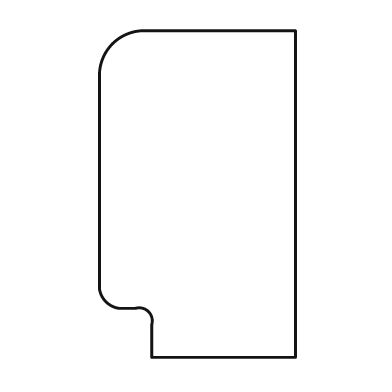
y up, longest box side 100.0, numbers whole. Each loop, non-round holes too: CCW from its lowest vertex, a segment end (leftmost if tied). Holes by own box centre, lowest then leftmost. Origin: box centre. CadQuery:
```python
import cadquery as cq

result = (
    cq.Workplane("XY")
    .moveTo(-14.0, -50.0)
    .lineTo(30.0, -50.0)
    .lineTo(30.0, 50.0)
    .lineTo(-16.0, 50.0)
    .threePointArc((-26.0, 46.0), (-30.0, 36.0))
    .lineTo(-30.0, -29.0)
    .threePointArc((-28.0, -33.0), (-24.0, -35.0))
    .lineTo(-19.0, -35.0)
    .threePointArc((-15.0, -36.0), (-14.0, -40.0))
    .close()
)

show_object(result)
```